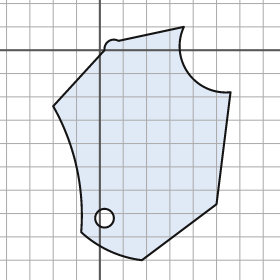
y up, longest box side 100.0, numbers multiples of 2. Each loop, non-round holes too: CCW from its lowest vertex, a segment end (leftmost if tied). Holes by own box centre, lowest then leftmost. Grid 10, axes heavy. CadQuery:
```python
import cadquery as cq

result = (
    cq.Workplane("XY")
    .moveTo(18.0, -90.0)
    .lineTo(50.0, -66.0)
    .lineTo(56.0, -18.0)
    .threePointArc((38.0, -10.0), (36.0, 10.0))
    .lineTo(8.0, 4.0)
    .threePointArc((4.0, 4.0), (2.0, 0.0))
    .lineTo(-20.0, -24.0)
    .threePointArc((-10.0, -50.0), (-8.0, -78.0))
    .threePointArc((4.0, -86.0), (18.0, -90.0))
    .close()
    .moveTo(2.0, -72.0)
    .circle(4.0)
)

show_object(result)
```